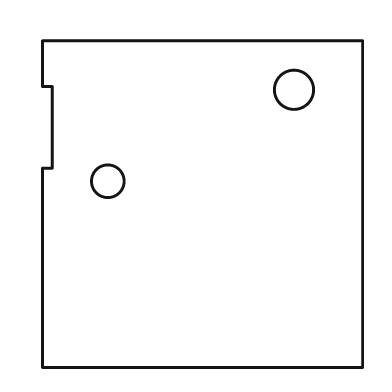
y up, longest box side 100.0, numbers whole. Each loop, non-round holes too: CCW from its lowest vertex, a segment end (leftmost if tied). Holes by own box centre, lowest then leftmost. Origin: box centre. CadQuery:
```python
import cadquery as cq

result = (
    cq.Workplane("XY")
    .moveTo(-49.0, -50.0)
    .lineTo(49.0, -50.0)
    .lineTo(49.0, 50.0)
    .lineTo(-49.0, 50.0)
    .lineTo(-49.0, 36.0)
    .lineTo(-46.0, 36.0)
    .lineTo(-46.0, 11.0)
    .lineTo(-49.0, 11.0)
    .close()
    .moveTo(-29.0, 7.0)
    .circle(5.0)
    .moveTo(28.0, 35.0)
    .circle(6.0)
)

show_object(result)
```